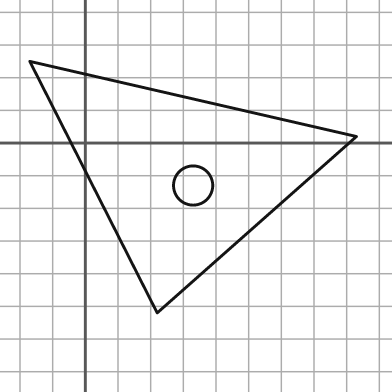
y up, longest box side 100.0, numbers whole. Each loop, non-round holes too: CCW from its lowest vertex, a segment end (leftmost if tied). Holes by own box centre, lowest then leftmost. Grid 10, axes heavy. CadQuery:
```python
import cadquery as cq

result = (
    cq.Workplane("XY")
    .moveTo(22.0, -52.0)
    .lineTo(83.0, 2.0)
    .lineTo(-17.0, 25.0)
    .close()
    .moveTo(33.0, -13.0)
    .circle(6.0)
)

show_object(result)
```